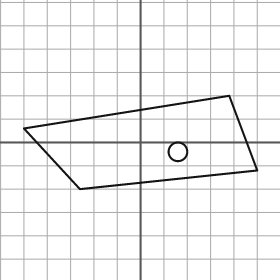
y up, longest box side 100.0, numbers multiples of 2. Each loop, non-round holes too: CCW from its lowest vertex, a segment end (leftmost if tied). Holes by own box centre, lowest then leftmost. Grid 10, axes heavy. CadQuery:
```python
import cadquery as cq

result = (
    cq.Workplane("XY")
    .moveTo(-26.0, -20.0)
    .lineTo(50.0, -12.0)
    .lineTo(38.0, 20.0)
    .lineTo(-50.0, 6.0)
    .close()
    .moveTo(16.0, -4.0)
    .circle(4.0)
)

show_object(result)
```